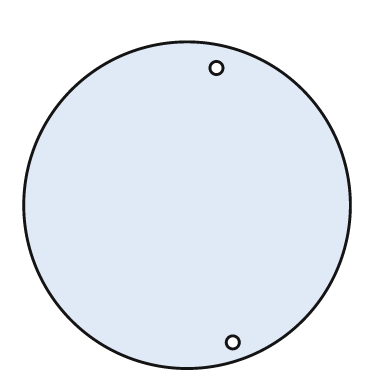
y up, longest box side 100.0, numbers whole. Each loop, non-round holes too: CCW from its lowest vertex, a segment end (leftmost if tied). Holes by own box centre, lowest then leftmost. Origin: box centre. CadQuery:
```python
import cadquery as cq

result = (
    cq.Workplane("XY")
    .moveTo(0.0, 0.0)
    .circle(50.0)
    .moveTo(14.0, -42.0)
    .circle(2.0)
    .moveTo(9.0, 42.0)
    .circle(2.0)
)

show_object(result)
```